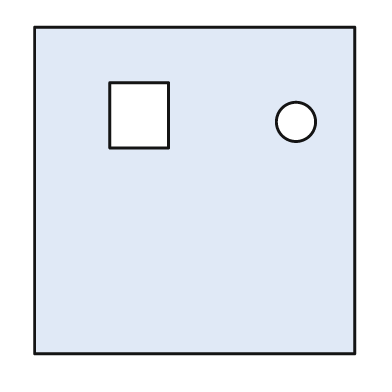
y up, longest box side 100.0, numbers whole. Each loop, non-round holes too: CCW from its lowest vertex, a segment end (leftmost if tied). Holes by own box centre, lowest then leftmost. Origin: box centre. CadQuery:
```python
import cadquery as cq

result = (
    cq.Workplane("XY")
    .moveTo(-49.0, -50.0)
    .lineTo(49.0, -50.0)
    .lineTo(49.0, 50.0)
    .lineTo(-49.0, 50.0)
    .close()
    .moveTo(31.0, 21.0)
    .circle(6.0)
    .moveTo(-26.0, 13.0)
    .lineTo(-8.0, 13.0)
    .lineTo(-8.0, 33.0)
    .lineTo(-26.0, 33.0)
    .close()
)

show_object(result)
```